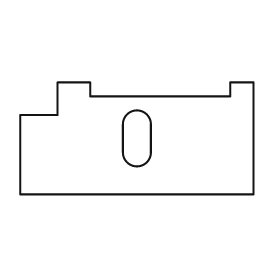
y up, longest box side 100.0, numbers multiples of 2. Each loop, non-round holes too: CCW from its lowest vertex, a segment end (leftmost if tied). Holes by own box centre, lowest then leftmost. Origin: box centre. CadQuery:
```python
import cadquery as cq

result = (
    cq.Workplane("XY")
    .moveTo(-50.0, -24.0)
    .lineTo(50.0, -24.0)
    .lineTo(50.0, 24.0)
    .lineTo(40.0, 24.0)
    .lineTo(40.0, 18.0)
    .lineTo(-20.0, 18.0)
    .lineTo(-20.0, 24.0)
    .lineTo(-34.0, 24.0)
    .lineTo(-34.0, 10.0)
    .lineTo(-50.0, 10.0)
    .close()
    .moveTo(-6.0, -6.0)
    .threePointArc((0.0, -12.0), (6.0, -6.0))
    .lineTo(6.0, 6.0)
    .threePointArc((0.0, 12.0), (-6.0, 6.0))
    .close()
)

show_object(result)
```